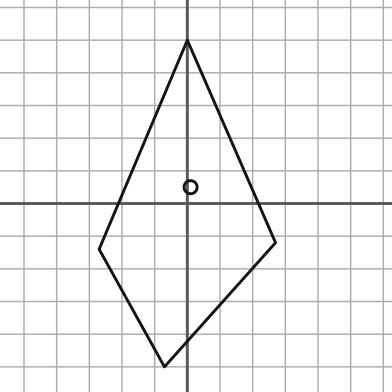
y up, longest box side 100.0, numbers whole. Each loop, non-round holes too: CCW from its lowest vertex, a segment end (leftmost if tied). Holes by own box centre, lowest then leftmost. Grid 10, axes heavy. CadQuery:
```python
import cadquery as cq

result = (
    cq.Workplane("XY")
    .moveTo(-7.0, -50.0)
    .lineTo(27.0, -12.0)
    .lineTo(0.0, 50.0)
    .lineTo(-27.0, -14.0)
    .close()
    .moveTo(1.0, 5.0)
    .circle(2.0)
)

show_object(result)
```